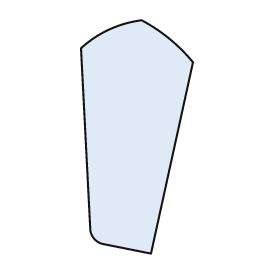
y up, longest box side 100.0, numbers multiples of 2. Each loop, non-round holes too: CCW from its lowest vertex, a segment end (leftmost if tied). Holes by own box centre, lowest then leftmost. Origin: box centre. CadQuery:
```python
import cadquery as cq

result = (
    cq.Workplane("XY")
    .moveTo(6.0, -50.0)
    .lineTo(24.0, 32.0)
    .threePointArc((14.0, 42.0), (2.0, 50.0))
    .threePointArc((-12.0, 46.0), (-24.0, 38.0))
    .lineTo(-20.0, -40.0)
    .threePointArc((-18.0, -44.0), (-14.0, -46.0))
    .close()
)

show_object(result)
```